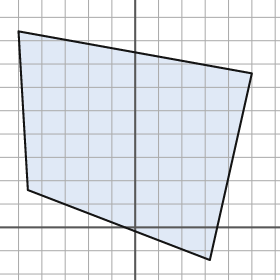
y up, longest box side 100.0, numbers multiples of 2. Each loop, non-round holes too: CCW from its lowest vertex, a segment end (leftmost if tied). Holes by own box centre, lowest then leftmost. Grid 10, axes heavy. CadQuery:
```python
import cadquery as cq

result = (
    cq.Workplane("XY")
    .moveTo(32.0, -14.0)
    .lineTo(50.0, 66.0)
    .lineTo(-50.0, 84.0)
    .lineTo(-46.0, 16.0)
    .close()
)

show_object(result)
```